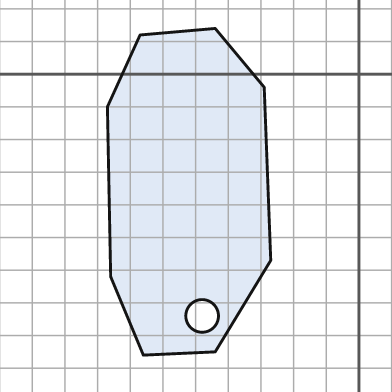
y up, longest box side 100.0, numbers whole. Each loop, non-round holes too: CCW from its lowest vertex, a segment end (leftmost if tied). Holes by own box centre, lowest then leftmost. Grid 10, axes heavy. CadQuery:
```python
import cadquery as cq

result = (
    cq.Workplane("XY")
    .moveTo(-66.0, -86.0)
    .lineTo(-44.0, -85.0)
    .lineTo(-27.0, -57.0)
    .lineTo(-29.0, -4.0)
    .lineTo(-44.0, 14.0)
    .lineTo(-67.0, 12.0)
    .lineTo(-77.0, -10.0)
    .lineTo(-76.0, -62.0)
    .close()
    .moveTo(-48.0, -74.0)
    .circle(5.0)
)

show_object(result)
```